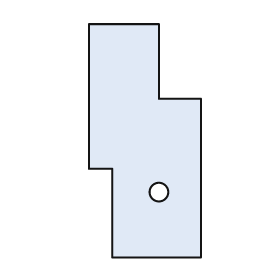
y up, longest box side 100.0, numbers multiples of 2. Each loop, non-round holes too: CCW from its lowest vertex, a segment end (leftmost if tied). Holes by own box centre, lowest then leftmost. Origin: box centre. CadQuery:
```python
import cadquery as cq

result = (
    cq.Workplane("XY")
    .moveTo(-14.0, -50.0)
    .lineTo(24.0, -50.0)
    .lineTo(24.0, 18.0)
    .lineTo(6.0, 18.0)
    .lineTo(6.0, 50.0)
    .lineTo(-24.0, 50.0)
    .lineTo(-24.0, -12.0)
    .lineTo(-14.0, -12.0)
    .close()
    .moveTo(6.0, -22.0)
    .circle(4.0)
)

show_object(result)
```